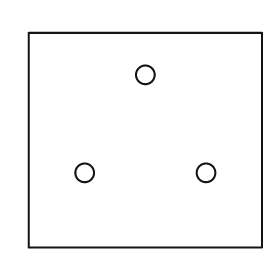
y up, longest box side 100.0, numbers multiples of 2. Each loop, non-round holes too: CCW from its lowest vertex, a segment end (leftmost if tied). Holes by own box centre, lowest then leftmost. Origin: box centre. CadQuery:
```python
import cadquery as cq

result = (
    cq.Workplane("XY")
    .moveTo(-50.0, -46.0)
    .lineTo(50.0, -46.0)
    .lineTo(50.0, 46.0)
    .lineTo(-50.0, 46.0)
    .close()
    .moveTo(-26.0, -14.0)
    .circle(4.0)
    .moveTo(26.0, -14.0)
    .circle(4.0)
    .moveTo(0.0, 28.0)
    .circle(4.0)
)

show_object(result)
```